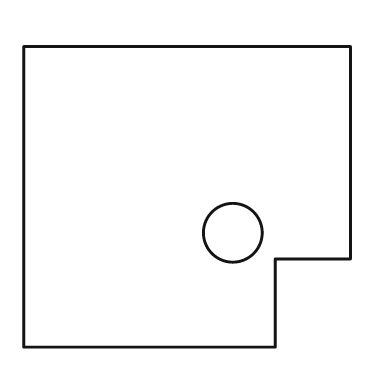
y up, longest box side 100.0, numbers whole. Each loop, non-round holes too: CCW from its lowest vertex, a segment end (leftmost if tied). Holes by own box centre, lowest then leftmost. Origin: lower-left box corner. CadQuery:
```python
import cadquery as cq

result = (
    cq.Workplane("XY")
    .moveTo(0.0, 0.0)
    .lineTo(77.0, 0.0)
    .lineTo(77.0, 27.0)
    .lineTo(100.0, 27.0)
    .lineTo(100.0, 92.0)
    .lineTo(0.0, 92.0)
    .close()
    .moveTo(64.0, 35.0)
    .circle(9.0)
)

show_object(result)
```